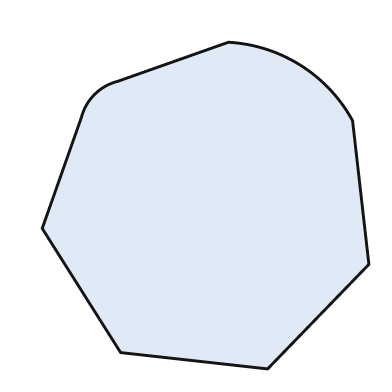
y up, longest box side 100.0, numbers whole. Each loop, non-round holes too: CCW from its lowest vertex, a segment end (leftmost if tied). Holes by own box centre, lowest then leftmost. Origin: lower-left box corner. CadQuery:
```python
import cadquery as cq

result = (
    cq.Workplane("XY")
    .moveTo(69.0, 0.0)
    .lineTo(100.0, 32.0)
    .lineTo(95.0, 76.0)
    .threePointArc((79.0, 93.0), (57.0, 100.0))
    .lineTo(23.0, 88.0)
    .threePointArc((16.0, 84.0), (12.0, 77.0))
    .lineTo(0.0, 43.0)
    .lineTo(24.0, 5.0)
    .close()
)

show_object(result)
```